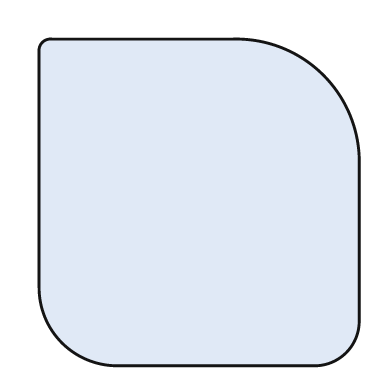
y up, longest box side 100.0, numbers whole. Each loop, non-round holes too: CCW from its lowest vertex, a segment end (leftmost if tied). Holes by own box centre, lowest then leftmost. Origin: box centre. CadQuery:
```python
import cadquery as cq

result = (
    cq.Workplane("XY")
    .moveTo(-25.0, -50.0)
    .lineTo(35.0, -50.0)
    .threePointArc((45.0, -46.0), (49.0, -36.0))
    .lineTo(49.0, 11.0)
    .threePointArc((38.0, 39.0), (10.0, 50.0))
    .lineTo(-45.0, 50.0)
    .threePointArc((-48.0, 49.0), (-49.0, 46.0))
    .lineTo(-49.0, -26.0)
    .threePointArc((-42.0, -43.0), (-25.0, -50.0))
    .close()
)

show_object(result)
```